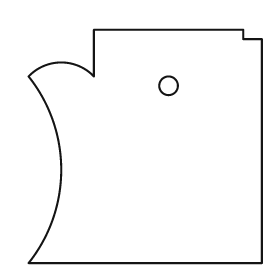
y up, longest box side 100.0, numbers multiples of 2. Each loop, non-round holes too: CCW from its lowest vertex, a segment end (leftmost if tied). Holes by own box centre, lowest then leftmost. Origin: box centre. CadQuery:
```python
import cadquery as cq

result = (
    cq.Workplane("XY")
    .moveTo(-50.0, -50.0)
    .lineTo(50.0, -50.0)
    .lineTo(50.0, 46.0)
    .lineTo(42.0, 46.0)
    .lineTo(42.0, 50.0)
    .lineTo(-22.0, 50.0)
    .lineTo(-22.0, 30.0)
    .threePointArc((-36.0, 36.0), (-50.0, 30.0))
    .threePointArc((-36.0, -10.0), (-50.0, -50.0))
    .close()
    .moveTo(10.0, 26.0)
    .circle(4.0)
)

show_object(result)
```